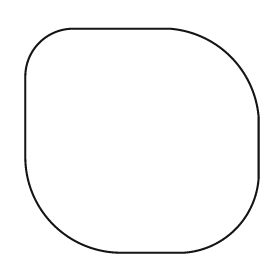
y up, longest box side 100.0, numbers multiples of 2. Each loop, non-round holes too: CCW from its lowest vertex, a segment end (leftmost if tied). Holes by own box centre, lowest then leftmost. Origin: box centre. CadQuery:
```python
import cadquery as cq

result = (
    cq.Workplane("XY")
    .moveTo(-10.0, -48.0)
    .lineTo(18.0, -48.0)
    .threePointArc((40.0, -38.0), (50.0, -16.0))
    .lineTo(50.0, 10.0)
    .threePointArc((38.0, 36.0), (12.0, 48.0))
    .lineTo(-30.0, 48.0)
    .threePointArc((-44.0, 42.0), (-50.0, 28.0))
    .lineTo(-50.0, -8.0)
    .threePointArc((-38.0, -36.0), (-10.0, -48.0))
    .close()
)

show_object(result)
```